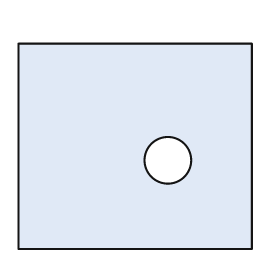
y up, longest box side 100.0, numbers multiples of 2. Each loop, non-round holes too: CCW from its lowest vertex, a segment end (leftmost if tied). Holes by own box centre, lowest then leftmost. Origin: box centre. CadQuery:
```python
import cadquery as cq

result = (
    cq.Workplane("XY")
    .moveTo(-50.0, -44.0)
    .lineTo(50.0, -44.0)
    .lineTo(50.0, 44.0)
    .lineTo(-50.0, 44.0)
    .close()
    .moveTo(14.0, -6.0)
    .circle(10.0)
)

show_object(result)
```